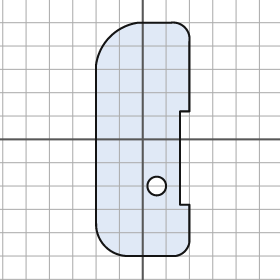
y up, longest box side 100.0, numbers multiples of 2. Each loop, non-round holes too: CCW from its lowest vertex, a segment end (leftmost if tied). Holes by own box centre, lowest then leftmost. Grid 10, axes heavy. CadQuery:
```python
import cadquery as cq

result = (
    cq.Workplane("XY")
    .moveTo(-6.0, -50.0)
    .lineTo(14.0, -50.0)
    .threePointArc((18.0, -48.0), (20.0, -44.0))
    .lineTo(20.0, -28.0)
    .lineTo(16.0, -28.0)
    .lineTo(16.0, 12.0)
    .lineTo(20.0, 12.0)
    .lineTo(20.0, 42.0)
    .threePointArc((18.0, 48.0), (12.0, 50.0))
    .lineTo(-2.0, 50.0)
    .threePointArc((-14.0, 44.0), (-20.0, 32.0))
    .lineTo(-20.0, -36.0)
    .threePointArc((-16.0, -46.0), (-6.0, -50.0))
    .close()
    .moveTo(6.0, -20.0)
    .circle(4.0)
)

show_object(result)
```